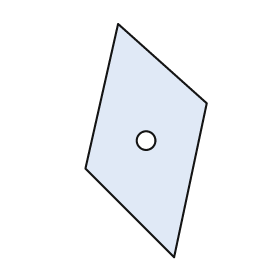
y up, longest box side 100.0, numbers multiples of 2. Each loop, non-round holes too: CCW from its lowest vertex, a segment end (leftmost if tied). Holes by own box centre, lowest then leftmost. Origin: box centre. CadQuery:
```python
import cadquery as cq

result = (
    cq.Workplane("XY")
    .moveTo(12.0, -50.0)
    .lineTo(26.0, 16.0)
    .lineTo(-12.0, 50.0)
    .lineTo(-26.0, -12.0)
    .close()
    .moveTo(0.0, 0.0)
    .circle(4.0)
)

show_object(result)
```